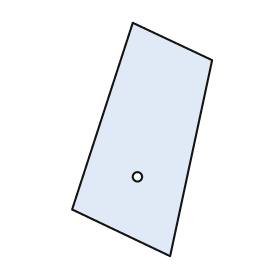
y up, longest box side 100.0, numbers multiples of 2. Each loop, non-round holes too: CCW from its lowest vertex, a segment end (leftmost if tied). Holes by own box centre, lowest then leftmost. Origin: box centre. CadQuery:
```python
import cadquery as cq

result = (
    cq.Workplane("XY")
    .moveTo(12.0, -50.0)
    .lineTo(30.0, 34.0)
    .lineTo(-4.0, 50.0)
    .lineTo(-30.0, -30.0)
    .close()
    .moveTo(-2.0, -16.0)
    .circle(2.0)
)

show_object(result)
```